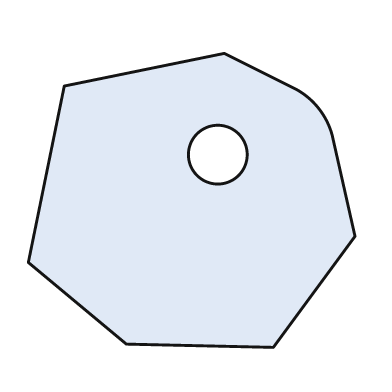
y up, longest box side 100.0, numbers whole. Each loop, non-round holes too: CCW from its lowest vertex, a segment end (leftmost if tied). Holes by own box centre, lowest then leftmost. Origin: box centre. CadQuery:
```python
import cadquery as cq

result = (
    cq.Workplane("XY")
    .moveTo(25.0, -45.0)
    .lineTo(50.0, -11.0)
    .lineTo(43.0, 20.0)
    .threePointArc((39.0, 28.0), (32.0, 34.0))
    .lineTo(10.0, 45.0)
    .lineTo(-39.0, 35.0)
    .lineTo(-50.0, -19.0)
    .lineTo(-20.0, -44.0)
    .close()
    .moveTo(8.0, 14.0)
    .circle(9.0)
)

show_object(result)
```